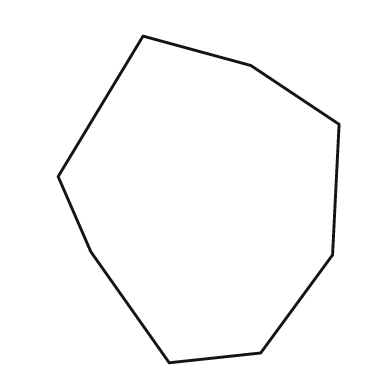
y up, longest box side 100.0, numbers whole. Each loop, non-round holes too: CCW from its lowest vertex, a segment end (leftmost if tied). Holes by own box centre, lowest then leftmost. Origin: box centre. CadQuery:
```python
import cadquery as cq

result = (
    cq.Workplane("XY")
    .moveTo(-9.0, -50.0)
    .lineTo(19.0, -47.0)
    .lineTo(41.0, -17.0)
    .lineTo(43.0, 23.0)
    .lineTo(16.0, 41.0)
    .lineTo(-17.0, 50.0)
    .lineTo(-43.0, 7.0)
    .lineTo(-33.0, -16.0)
    .close()
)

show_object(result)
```